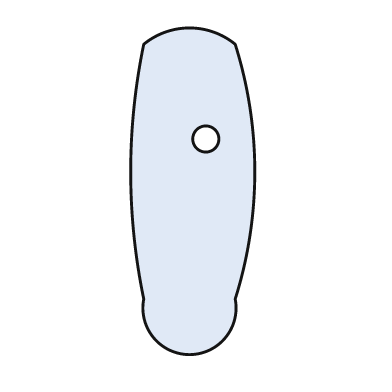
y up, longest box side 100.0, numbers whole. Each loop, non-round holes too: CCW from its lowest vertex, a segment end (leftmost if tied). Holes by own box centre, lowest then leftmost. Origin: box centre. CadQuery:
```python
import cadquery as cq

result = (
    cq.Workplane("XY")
    .moveTo(-15.0, -33.0)
    .threePointArc((-1.0, -50.0), (13.0, -33.0))
    .threePointArc((19.0, 6.0), (13.0, 45.0))
    .threePointArc((-1.0, 50.0), (-15.0, 45.0))
    .threePointArc((-19.0, 6.0), (-15.0, -33.0))
    .close()
    .moveTo(4.0, 16.0)
    .circle(4.0)
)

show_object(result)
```